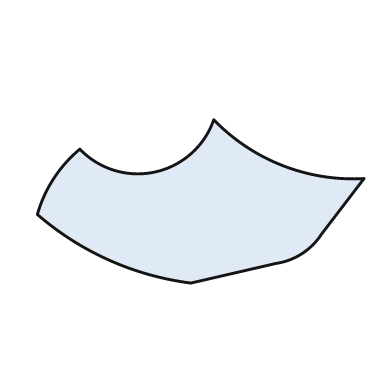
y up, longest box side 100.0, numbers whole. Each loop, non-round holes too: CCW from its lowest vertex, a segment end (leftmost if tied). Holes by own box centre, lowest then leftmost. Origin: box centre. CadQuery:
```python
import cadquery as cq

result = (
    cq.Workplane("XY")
    .moveTo(-3.0, -25.0)
    .lineTo(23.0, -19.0)
    .threePointArc((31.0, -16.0), (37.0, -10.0))
    .lineTo(50.0, 7.0)
    .threePointArc((25.0, 11.0), (4.0, 25.0))
    .threePointArc((-14.0, 9.0), (-37.0, 16.0))
    .threePointArc((-45.0, 7.0), (-50.0, -4.0))
    .threePointArc((-28.0, -18.0), (-3.0, -25.0))
    .close()
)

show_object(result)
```